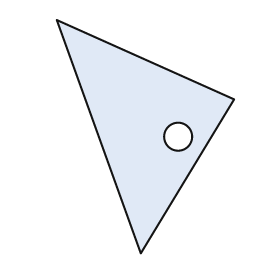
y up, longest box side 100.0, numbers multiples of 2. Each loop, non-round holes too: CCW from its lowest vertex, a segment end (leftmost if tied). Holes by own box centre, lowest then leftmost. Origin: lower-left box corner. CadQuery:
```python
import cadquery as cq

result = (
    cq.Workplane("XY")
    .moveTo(36.0, 0.0)
    .lineTo(76.0, 66.0)
    .lineTo(0.0, 100.0)
    .close()
    .moveTo(52.0, 50.0)
    .circle(6.0)
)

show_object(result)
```